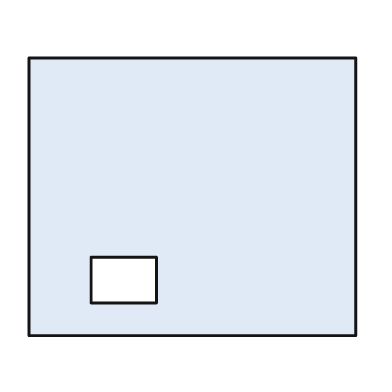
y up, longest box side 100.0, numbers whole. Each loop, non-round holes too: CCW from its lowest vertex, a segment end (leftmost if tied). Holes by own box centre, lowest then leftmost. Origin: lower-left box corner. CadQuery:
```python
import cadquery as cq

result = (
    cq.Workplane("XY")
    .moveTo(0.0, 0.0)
    .lineTo(100.0, 0.0)
    .lineTo(100.0, 85.0)
    .lineTo(0.0, 85.0)
    .close()
    .moveTo(19.0, 10.0)
    .lineTo(39.0, 10.0)
    .lineTo(39.0, 24.0)
    .lineTo(19.0, 24.0)
    .close()
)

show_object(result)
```